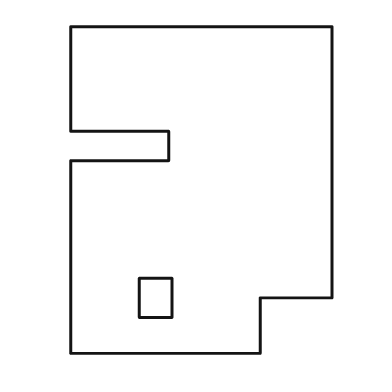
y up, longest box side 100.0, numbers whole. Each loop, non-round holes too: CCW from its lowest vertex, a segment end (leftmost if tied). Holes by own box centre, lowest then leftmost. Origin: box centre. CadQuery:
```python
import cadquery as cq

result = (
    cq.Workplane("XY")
    .moveTo(-40.0, -50.0)
    .lineTo(18.0, -50.0)
    .lineTo(18.0, -33.0)
    .lineTo(40.0, -33.0)
    .lineTo(40.0, 50.0)
    .lineTo(-40.0, 50.0)
    .lineTo(-40.0, 18.0)
    .lineTo(-10.0, 18.0)
    .lineTo(-10.0, 9.0)
    .lineTo(-40.0, 9.0)
    .close()
    .moveTo(-19.0, -39.0)
    .lineTo(-9.0, -39.0)
    .lineTo(-9.0, -27.0)
    .lineTo(-19.0, -27.0)
    .close()
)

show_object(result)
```